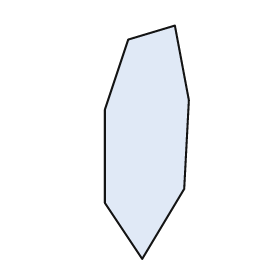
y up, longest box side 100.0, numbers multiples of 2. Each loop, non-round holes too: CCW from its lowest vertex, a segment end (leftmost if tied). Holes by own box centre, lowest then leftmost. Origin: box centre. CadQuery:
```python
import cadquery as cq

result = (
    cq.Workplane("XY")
    .moveTo(-2.0, -50.0)
    .lineTo(16.0, -20.0)
    .lineTo(18.0, 18.0)
    .lineTo(12.0, 50.0)
    .lineTo(-8.0, 44.0)
    .lineTo(-18.0, 14.0)
    .lineTo(-18.0, -26.0)
    .close()
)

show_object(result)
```